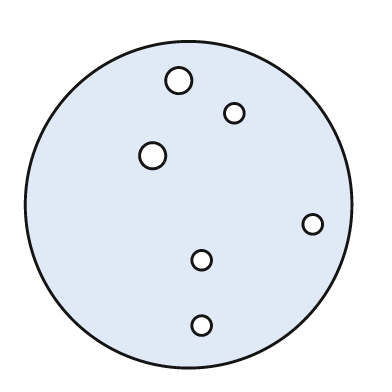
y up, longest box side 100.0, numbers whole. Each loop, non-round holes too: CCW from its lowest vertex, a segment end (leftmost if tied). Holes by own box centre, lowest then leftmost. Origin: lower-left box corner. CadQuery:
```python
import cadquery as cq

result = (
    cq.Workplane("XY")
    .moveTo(50.0, 50.0)
    .circle(50.0)
    .moveTo(54.0, 13.0)
    .circle(3.0)
    .moveTo(54.0, 33.0)
    .circle(3.0)
    .moveTo(88.0, 44.0)
    .circle(3.0)
    .moveTo(39.0, 65.0)
    .circle(4.0)
    .moveTo(64.0, 78.0)
    .circle(3.0)
    .moveTo(47.0, 88.0)
    .circle(4.0)
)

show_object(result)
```